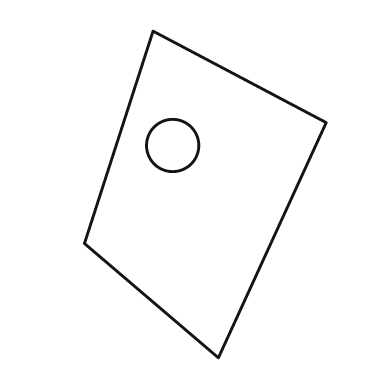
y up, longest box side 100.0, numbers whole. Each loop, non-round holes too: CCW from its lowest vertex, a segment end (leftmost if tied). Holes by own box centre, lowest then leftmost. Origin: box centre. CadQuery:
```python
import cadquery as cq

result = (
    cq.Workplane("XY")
    .moveTo(4.0, -50.0)
    .lineTo(37.0, 22.0)
    .lineTo(-16.0, 50.0)
    .lineTo(-37.0, -15.0)
    .close()
    .moveTo(-10.0, 15.0)
    .circle(8.0)
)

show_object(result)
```